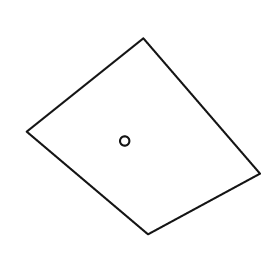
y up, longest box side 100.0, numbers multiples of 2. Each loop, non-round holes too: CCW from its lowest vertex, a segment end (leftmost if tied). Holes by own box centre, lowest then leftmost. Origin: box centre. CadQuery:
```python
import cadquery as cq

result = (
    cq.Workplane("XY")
    .moveTo(2.0, -42.0)
    .lineTo(50.0, -16.0)
    .lineTo(0.0, 42.0)
    .lineTo(-50.0, 2.0)
    .close()
    .moveTo(-8.0, -2.0)
    .circle(2.0)
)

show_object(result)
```